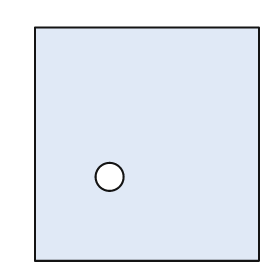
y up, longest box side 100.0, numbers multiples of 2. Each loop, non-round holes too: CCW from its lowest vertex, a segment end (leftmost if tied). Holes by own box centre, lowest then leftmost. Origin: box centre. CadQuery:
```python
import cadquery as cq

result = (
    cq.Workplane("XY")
    .moveTo(-48.0, -50.0)
    .lineTo(48.0, -50.0)
    .lineTo(48.0, 50.0)
    .lineTo(-48.0, 50.0)
    .close()
    .moveTo(-16.0, -14.0)
    .circle(6.0)
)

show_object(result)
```